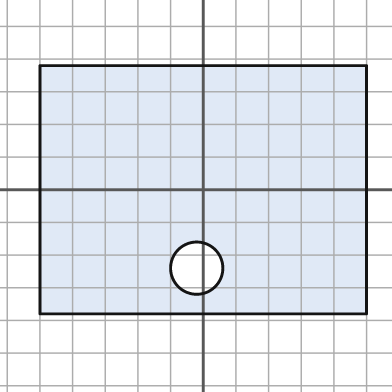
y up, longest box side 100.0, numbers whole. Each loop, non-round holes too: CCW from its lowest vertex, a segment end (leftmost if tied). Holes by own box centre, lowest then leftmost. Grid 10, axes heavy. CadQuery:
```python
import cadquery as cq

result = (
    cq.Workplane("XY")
    .moveTo(-50.0, -38.0)
    .lineTo(50.0, -38.0)
    .lineTo(50.0, 38.0)
    .lineTo(-50.0, 38.0)
    .close()
    .moveTo(-2.0, -24.0)
    .circle(8.0)
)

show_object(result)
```